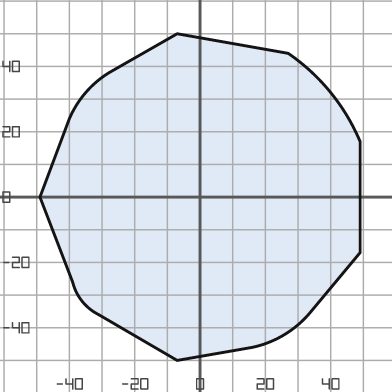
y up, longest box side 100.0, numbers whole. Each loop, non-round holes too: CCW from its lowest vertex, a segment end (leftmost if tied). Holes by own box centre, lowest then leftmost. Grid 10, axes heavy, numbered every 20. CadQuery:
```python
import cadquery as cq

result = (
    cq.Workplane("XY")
    .moveTo(-7.0, -50.0)
    .lineTo(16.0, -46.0)
    .threePointArc((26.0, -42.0), (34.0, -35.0))
    .lineTo(49.0, -17.0)
    .lineTo(49.0, 17.0)
    .threePointArc((40.0, 32.0), (27.0, 44.0))
    .lineTo(-7.0, 50.0)
    .lineTo(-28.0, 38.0)
    .threePointArc((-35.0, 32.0), (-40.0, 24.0))
    .lineTo(-49.0, 0.0)
    .lineTo(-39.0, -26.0)
    .threePointArc((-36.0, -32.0), (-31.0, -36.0))
    .close()
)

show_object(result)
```